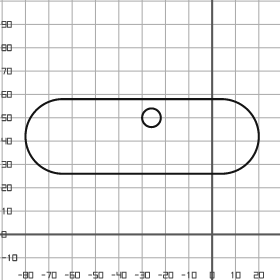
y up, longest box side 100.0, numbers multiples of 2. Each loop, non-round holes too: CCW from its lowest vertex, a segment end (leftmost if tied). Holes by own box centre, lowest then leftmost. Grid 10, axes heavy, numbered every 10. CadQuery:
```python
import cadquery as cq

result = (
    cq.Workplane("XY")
    .moveTo(-64.0, 26.0)
    .lineTo(4.0, 26.0)
    .threePointArc((20.0, 42.0), (4.0, 58.0))
    .lineTo(-64.0, 58.0)
    .threePointArc((-80.0, 42.0), (-64.0, 26.0))
    .close()
    .moveTo(-26.0, 50.0)
    .circle(4.0)
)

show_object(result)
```